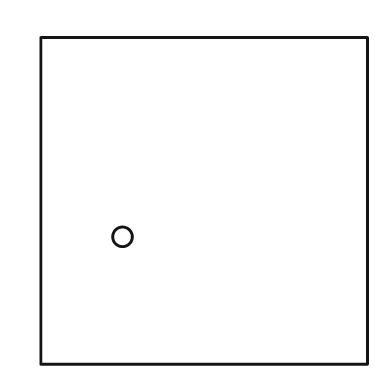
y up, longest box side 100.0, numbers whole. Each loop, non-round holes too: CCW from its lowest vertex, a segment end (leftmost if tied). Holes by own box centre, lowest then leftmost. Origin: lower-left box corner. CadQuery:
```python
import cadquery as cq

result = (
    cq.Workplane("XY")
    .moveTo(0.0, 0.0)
    .lineTo(100.0, 0.0)
    .lineTo(100.0, 100.0)
    .lineTo(0.0, 100.0)
    .close()
    .moveTo(25.0, 39.0)
    .circle(3.0)
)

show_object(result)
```